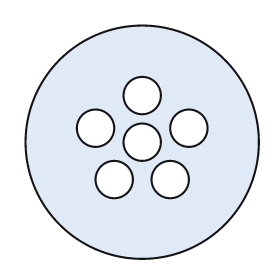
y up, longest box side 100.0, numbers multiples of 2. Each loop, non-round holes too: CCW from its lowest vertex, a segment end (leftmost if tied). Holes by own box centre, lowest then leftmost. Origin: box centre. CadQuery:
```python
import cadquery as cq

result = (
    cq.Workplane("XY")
    .moveTo(0.0, 0.0)
    .circle(50.0)
    .moveTo(-12.0, -16.0)
    .circle(8.0)
    .moveTo(12.0, -16.0)
    .circle(8.0)
    .moveTo(0.0, 0.0)
    .circle(8.0)
    .moveTo(-20.0, 6.0)
    .circle(8.0)
    .moveTo(20.0, 6.0)
    .circle(8.0)
    .moveTo(0.0, 20.0)
    .circle(8.0)
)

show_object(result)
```